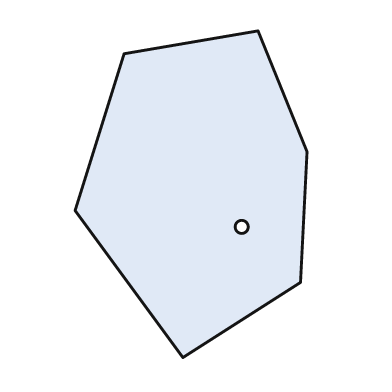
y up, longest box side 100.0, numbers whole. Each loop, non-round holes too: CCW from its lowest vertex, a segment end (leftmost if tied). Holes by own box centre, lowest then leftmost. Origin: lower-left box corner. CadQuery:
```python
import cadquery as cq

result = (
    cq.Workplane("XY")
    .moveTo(33.0, 0.0)
    .lineTo(69.0, 23.0)
    .lineTo(71.0, 63.0)
    .lineTo(56.0, 100.0)
    .lineTo(15.0, 93.0)
    .lineTo(0.0, 45.0)
    .close()
    .moveTo(51.0, 40.0)
    .circle(2.0)
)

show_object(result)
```